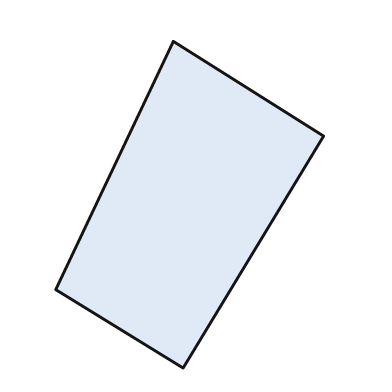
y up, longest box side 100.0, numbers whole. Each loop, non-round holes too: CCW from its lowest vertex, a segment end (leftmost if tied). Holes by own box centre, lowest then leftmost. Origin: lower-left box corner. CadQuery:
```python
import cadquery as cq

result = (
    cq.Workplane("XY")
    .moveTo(39.0, 0.0)
    .lineTo(82.0, 71.0)
    .lineTo(36.0, 100.0)
    .lineTo(0.0, 24.0)
    .close()
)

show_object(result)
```